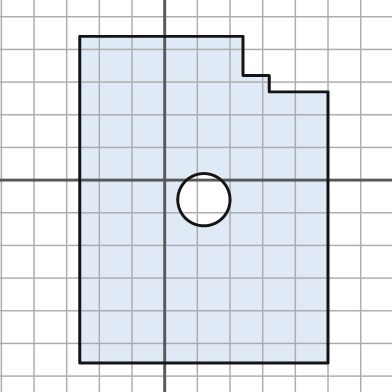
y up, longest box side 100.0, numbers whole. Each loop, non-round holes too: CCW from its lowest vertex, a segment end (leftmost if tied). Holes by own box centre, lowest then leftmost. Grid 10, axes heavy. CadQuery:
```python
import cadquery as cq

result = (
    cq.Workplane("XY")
    .moveTo(-26.0, -56.0)
    .lineTo(50.0, -56.0)
    .lineTo(50.0, 27.0)
    .lineTo(32.0, 27.0)
    .lineTo(32.0, 32.0)
    .lineTo(24.0, 32.0)
    .lineTo(24.0, 44.0)
    .lineTo(-26.0, 44.0)
    .close()
    .moveTo(12.0, -6.0)
    .circle(8.0)
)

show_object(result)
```